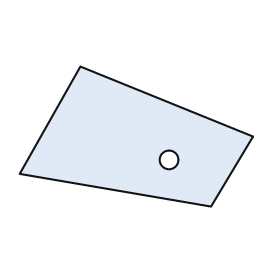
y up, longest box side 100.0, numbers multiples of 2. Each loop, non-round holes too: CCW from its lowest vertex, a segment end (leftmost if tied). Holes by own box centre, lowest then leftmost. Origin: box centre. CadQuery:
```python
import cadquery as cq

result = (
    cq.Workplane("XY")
    .moveTo(32.0, -30.0)
    .lineTo(50.0, 0.0)
    .lineTo(-24.0, 30.0)
    .lineTo(-50.0, -16.0)
    .close()
    .moveTo(14.0, -10.0)
    .circle(4.0)
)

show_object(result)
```